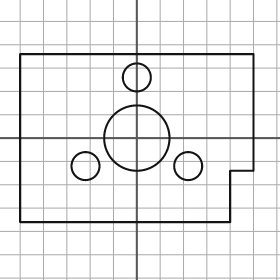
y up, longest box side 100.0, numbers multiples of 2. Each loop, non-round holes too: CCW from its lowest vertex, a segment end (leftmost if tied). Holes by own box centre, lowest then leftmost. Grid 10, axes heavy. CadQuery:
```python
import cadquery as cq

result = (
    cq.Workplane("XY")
    .moveTo(-50.0, -36.0)
    .lineTo(40.0, -36.0)
    .lineTo(40.0, -14.0)
    .lineTo(50.0, -14.0)
    .lineTo(50.0, 36.0)
    .lineTo(-50.0, 36.0)
    .close()
    .moveTo(-22.0, -12.0)
    .circle(6.0)
    .moveTo(22.0, -12.0)
    .circle(6.0)
    .moveTo(0.0, 0.0)
    .circle(14.0)
    .moveTo(0.0, 26.0)
    .circle(6.0)
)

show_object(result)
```